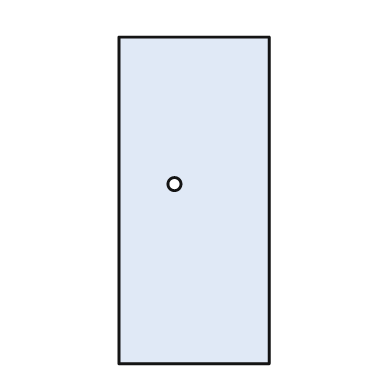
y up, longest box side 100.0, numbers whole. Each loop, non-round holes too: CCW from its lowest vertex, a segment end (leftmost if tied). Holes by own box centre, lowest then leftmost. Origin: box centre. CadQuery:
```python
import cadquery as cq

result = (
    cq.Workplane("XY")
    .moveTo(-23.0, -50.0)
    .lineTo(23.0, -50.0)
    .lineTo(23.0, 50.0)
    .lineTo(-23.0, 50.0)
    .close()
    .moveTo(-6.0, 5.0)
    .circle(2.0)
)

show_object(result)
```